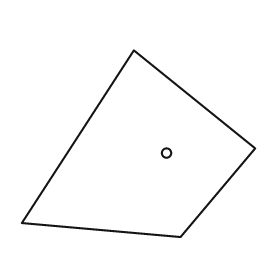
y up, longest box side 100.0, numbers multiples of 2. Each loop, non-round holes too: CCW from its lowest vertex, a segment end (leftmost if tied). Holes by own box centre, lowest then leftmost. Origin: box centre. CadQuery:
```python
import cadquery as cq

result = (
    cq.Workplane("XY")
    .moveTo(18.0, -40.0)
    .lineTo(50.0, -2.0)
    .lineTo(-2.0, 40.0)
    .lineTo(-50.0, -34.0)
    .close()
    .moveTo(12.0, -4.0)
    .circle(2.0)
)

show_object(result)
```